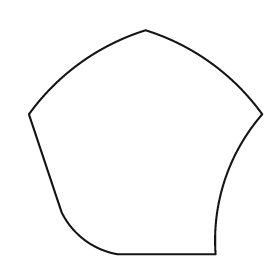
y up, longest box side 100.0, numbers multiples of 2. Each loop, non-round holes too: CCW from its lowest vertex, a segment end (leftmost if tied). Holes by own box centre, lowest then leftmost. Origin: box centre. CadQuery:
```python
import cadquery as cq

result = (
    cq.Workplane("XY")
    .moveTo(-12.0, -48.0)
    .lineTo(30.0, -48.0)
    .threePointArc((34.0, -16.0), (50.0, 12.0))
    .threePointArc((28.0, 34.0), (0.0, 48.0))
    .threePointArc((-28.0, 34.0), (-50.0, 12.0))
    .lineTo(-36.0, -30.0)
    .threePointArc((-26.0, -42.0), (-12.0, -48.0))
    .close()
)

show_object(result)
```